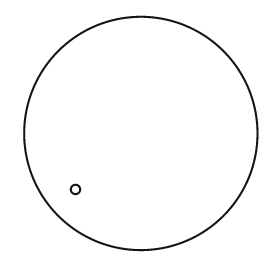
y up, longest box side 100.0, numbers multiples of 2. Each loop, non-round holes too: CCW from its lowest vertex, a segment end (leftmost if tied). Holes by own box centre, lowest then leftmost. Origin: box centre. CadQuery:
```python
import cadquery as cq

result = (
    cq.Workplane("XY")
    .moveTo(0.0, 0.0)
    .circle(50.0)
    .moveTo(-28.0, -24.0)
    .circle(2.0)
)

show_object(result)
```